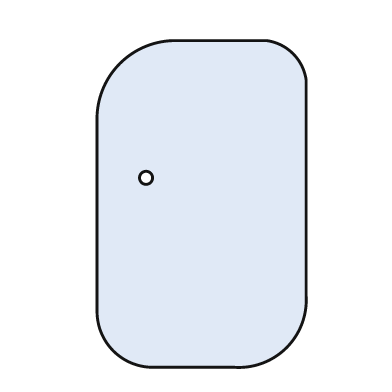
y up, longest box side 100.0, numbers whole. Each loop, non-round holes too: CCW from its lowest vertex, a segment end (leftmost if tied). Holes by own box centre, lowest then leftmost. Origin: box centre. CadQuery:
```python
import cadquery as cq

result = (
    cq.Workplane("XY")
    .moveTo(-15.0, -50.0)
    .lineTo(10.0, -50.0)
    .threePointArc((26.0, -44.0), (32.0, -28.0))
    .lineTo(32.0, 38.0)
    .threePointArc((28.0, 46.0), (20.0, 50.0))
    .lineTo(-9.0, 50.0)
    .threePointArc((-25.0, 43.0), (-32.0, 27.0))
    .lineTo(-32.0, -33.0)
    .threePointArc((-27.0, -45.0), (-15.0, -50.0))
    .close()
    .moveTo(-17.0, 8.0)
    .circle(2.0)
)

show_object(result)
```